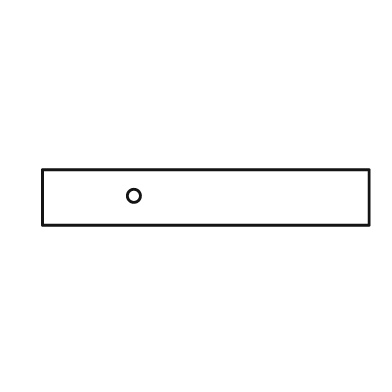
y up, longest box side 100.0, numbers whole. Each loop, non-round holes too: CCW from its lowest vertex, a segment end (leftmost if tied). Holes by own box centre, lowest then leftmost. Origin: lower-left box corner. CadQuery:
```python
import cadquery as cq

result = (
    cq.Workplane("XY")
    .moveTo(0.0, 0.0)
    .lineTo(100.0, 0.0)
    .lineTo(100.0, 17.0)
    .lineTo(0.0, 17.0)
    .close()
    .moveTo(28.0, 9.0)
    .circle(2.0)
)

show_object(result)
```